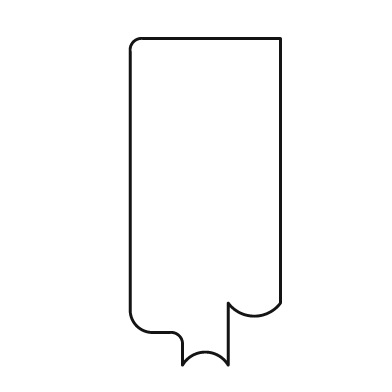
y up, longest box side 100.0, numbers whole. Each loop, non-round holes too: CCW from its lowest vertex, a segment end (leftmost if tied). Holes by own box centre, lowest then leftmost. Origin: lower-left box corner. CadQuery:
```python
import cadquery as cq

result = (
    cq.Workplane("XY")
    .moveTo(16.0, 0.0)
    .threePointArc((23.0, 4.0), (30.0, 0.0))
    .lineTo(30.0, 19.0)
    .threePointArc((38.0, 15.0), (46.0, 19.0))
    .lineTo(46.0, 100.0)
    .lineTo(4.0, 100.0)
    .threePointArc((1.0, 99.0), (0.0, 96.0))
    .lineTo(0.0, 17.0)
    .threePointArc((2.0, 12.0), (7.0, 10.0))
    .lineTo(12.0, 10.0)
    .threePointArc((15.0, 9.0), (16.0, 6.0))
    .close()
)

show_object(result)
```